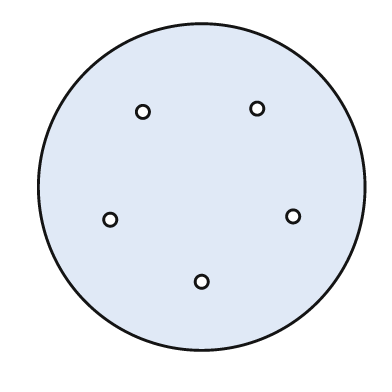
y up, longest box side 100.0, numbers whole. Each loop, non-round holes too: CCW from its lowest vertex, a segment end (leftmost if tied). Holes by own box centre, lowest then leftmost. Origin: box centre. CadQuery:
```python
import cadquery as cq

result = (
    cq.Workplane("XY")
    .moveTo(0.0, 0.0)
    .circle(50.0)
    .moveTo(0.0, -29.0)
    .circle(2.0)
    .moveTo(-28.0, -10.0)
    .circle(2.0)
    .moveTo(28.0, -9.0)
    .circle(2.0)
    .moveTo(-18.0, 23.0)
    .circle(2.0)
    .moveTo(17.0, 24.0)
    .circle(2.0)
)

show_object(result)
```